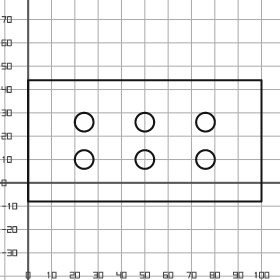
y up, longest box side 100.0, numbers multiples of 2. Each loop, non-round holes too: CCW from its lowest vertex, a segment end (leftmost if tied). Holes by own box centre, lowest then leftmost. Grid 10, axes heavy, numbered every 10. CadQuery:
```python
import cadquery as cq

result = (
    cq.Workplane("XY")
    .moveTo(0.0, -8.0)
    .lineTo(100.0, -8.0)
    .lineTo(100.0, 44.0)
    .lineTo(0.0, 44.0)
    .close()
    .moveTo(24.0, 10.0)
    .circle(4.0)
    .moveTo(50.0, 10.0)
    .circle(4.0)
    .moveTo(76.0, 10.0)
    .circle(4.0)
    .moveTo(24.0, 26.0)
    .circle(4.0)
    .moveTo(50.0, 26.0)
    .circle(4.0)
    .moveTo(76.0, 26.0)
    .circle(4.0)
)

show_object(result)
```